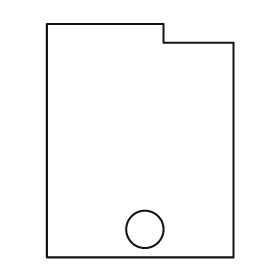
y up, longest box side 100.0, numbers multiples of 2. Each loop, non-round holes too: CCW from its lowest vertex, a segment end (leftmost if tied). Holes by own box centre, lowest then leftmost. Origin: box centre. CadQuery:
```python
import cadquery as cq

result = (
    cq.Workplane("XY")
    .moveTo(-40.0, -50.0)
    .lineTo(40.0, -50.0)
    .lineTo(40.0, 42.0)
    .lineTo(10.0, 42.0)
    .lineTo(10.0, 50.0)
    .lineTo(-40.0, 50.0)
    .close()
    .moveTo(2.0, -38.0)
    .circle(8.0)
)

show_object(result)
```